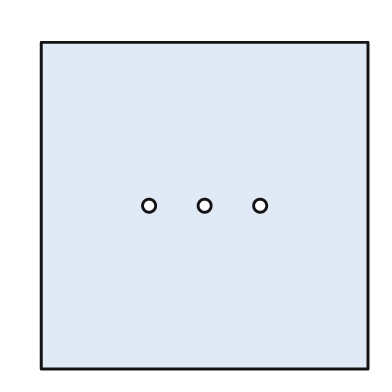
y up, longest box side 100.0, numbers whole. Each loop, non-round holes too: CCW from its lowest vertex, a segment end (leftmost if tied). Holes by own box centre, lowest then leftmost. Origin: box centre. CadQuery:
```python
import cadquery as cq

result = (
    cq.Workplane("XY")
    .moveTo(-50.0, -50.0)
    .lineTo(50.0, -50.0)
    .lineTo(50.0, 50.0)
    .lineTo(-50.0, 50.0)
    .close()
    .moveTo(-17.0, 0.0)
    .circle(2.0)
    .moveTo(0.0, 0.0)
    .circle(2.0)
    .moveTo(17.0, 0.0)
    .circle(2.0)
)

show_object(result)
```